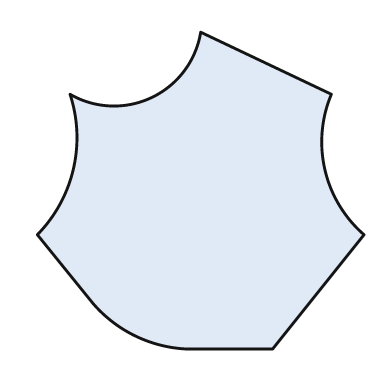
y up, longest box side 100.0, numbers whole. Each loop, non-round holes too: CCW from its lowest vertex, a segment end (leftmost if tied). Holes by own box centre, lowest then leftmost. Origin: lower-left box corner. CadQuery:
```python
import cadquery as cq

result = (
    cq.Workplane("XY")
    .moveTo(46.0, 0.0)
    .lineTo(72.0, 0.0)
    .lineTo(100.0, 35.0)
    .threePointArc((88.0, 55.0), (90.0, 78.0))
    .lineTo(50.0, 97.0)
    .threePointArc((35.0, 77.0), (10.0, 78.0))
    .threePointArc((11.0, 55.0), (0.0, 35.0))
    .lineTo(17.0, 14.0)
    .threePointArc((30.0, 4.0), (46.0, 0.0))
    .close()
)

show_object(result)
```